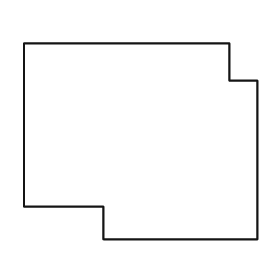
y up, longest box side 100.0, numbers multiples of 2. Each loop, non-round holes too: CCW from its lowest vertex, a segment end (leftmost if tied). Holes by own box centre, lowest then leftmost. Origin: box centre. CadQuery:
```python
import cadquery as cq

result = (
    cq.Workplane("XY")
    .moveTo(-16.0, -42.0)
    .lineTo(50.0, -42.0)
    .lineTo(50.0, 26.0)
    .lineTo(38.0, 26.0)
    .lineTo(38.0, 42.0)
    .lineTo(-50.0, 42.0)
    .lineTo(-50.0, -28.0)
    .lineTo(-16.0, -28.0)
    .close()
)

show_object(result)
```